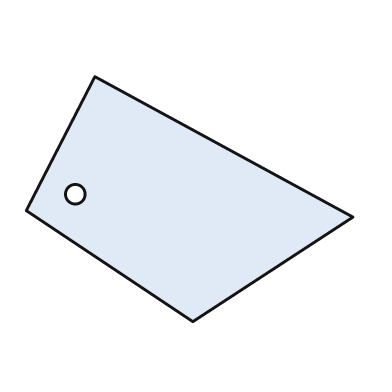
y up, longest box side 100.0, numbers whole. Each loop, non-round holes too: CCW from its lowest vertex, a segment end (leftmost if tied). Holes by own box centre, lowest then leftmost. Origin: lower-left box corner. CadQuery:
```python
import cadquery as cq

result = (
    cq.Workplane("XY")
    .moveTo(51.0, 0.0)
    .lineTo(100.0, 32.0)
    .lineTo(21.0, 75.0)
    .lineTo(0.0, 34.0)
    .close()
    .moveTo(15.0, 39.0)
    .circle(3.0)
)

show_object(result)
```